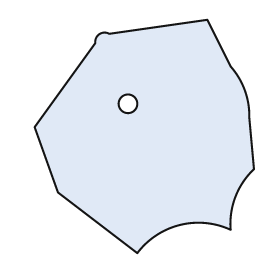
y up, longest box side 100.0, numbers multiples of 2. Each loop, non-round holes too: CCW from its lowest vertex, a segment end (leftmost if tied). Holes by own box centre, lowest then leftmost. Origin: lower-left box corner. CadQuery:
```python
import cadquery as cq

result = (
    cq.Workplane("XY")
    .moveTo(44.0, 0.0)
    .threePointArc((62.0, 12.0), (84.0, 10.0))
    .threePointArc((86.0, 24.0), (94.0, 36.0))
    .lineTo(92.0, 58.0)
    .threePointArc((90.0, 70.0), (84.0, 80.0))
    .lineTo(74.0, 100.0)
    .lineTo(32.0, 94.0)
    .threePointArc((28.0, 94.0), (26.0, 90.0))
    .lineTo(0.0, 54.0)
    .lineTo(10.0, 26.0)
    .close()
    .moveTo(40.0, 64.0)
    .circle(4.0)
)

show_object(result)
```